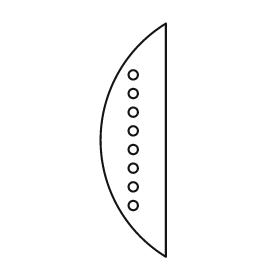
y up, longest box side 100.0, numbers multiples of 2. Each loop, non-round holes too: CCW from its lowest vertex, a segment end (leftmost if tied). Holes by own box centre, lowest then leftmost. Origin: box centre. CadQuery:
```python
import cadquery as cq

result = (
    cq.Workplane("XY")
    .moveTo(14.0, -50.0)
    .lineTo(14.0, 50.0)
    .threePointArc((-14.0, 0.0), (14.0, -50.0))
    .close()
    .moveTo(0.0, -28.0)
    .circle(2.0)
    .moveTo(0.0, -20.0)
    .circle(2.0)
    .moveTo(0.0, -12.0)
    .circle(2.0)
    .moveTo(0.0, -4.0)
    .circle(2.0)
    .moveTo(0.0, 4.0)
    .circle(2.0)
    .moveTo(0.0, 12.0)
    .circle(2.0)
    .moveTo(0.0, 20.0)
    .circle(2.0)
    .moveTo(0.0, 28.0)
    .circle(2.0)
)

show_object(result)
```